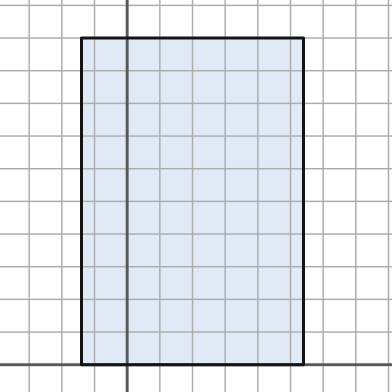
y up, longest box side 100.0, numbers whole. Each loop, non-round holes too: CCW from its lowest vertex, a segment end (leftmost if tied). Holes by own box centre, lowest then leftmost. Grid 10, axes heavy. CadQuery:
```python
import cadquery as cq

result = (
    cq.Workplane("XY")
    .moveTo(-14.0, 0.0)
    .lineTo(54.0, 0.0)
    .lineTo(54.0, 100.0)
    .lineTo(-14.0, 100.0)
    .close()
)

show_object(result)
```